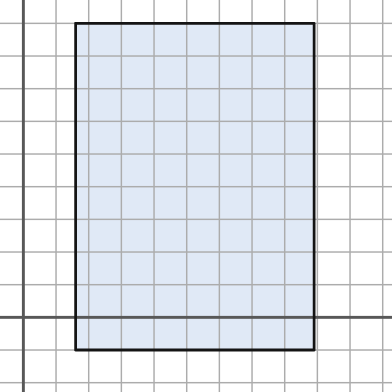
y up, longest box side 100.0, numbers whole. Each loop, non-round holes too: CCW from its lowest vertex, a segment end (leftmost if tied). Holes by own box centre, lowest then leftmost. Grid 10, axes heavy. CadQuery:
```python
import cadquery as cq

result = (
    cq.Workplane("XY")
    .moveTo(16.0, -10.0)
    .lineTo(89.0, -10.0)
    .lineTo(89.0, 90.0)
    .lineTo(16.0, 90.0)
    .close()
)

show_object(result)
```